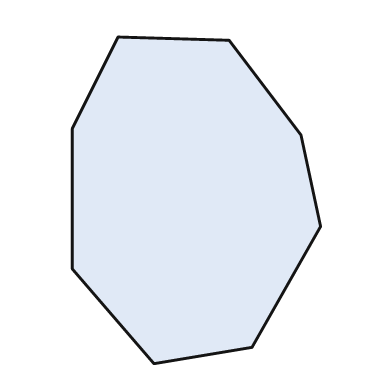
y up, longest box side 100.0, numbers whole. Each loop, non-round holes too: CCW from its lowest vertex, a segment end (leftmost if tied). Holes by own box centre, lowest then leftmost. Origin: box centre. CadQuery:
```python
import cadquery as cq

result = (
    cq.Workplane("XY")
    .moveTo(-13.0, -50.0)
    .lineTo(17.0, -45.0)
    .lineTo(38.0, -8.0)
    .lineTo(32.0, 20.0)
    .lineTo(10.0, 49.0)
    .lineTo(-24.0, 50.0)
    .lineTo(-38.0, 22.0)
    .lineTo(-38.0, -21.0)
    .close()
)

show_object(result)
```